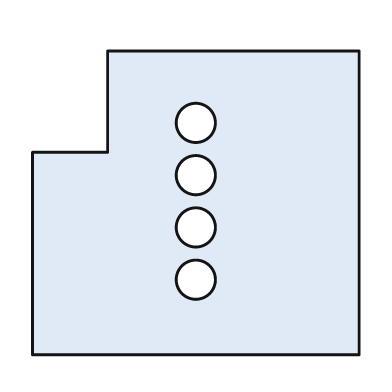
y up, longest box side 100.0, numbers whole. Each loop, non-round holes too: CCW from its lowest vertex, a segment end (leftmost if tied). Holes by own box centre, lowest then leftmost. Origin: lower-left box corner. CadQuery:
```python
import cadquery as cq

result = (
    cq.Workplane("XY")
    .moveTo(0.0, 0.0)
    .lineTo(100.0, 0.0)
    .lineTo(100.0, 93.0)
    .lineTo(23.0, 93.0)
    .lineTo(23.0, 62.0)
    .lineTo(0.0, 62.0)
    .close()
    .moveTo(50.0, 23.0)
    .circle(6.0)
    .moveTo(50.0, 39.0)
    .circle(6.0)
    .moveTo(50.0, 55.0)
    .circle(6.0)
    .moveTo(50.0, 71.0)
    .circle(6.0)
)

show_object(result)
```